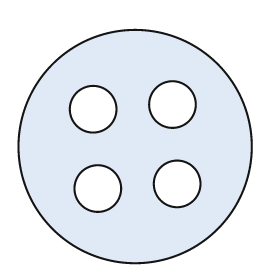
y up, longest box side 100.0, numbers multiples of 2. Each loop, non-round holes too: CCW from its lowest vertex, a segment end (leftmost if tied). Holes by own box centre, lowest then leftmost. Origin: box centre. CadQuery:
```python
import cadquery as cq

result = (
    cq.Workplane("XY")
    .moveTo(0.0, 0.0)
    .circle(50.0)
    .moveTo(-16.0, -18.0)
    .circle(10.0)
    .moveTo(18.0, -16.0)
    .circle(10.0)
    .moveTo(-18.0, 16.0)
    .circle(10.0)
    .moveTo(16.0, 18.0)
    .circle(10.0)
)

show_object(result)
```